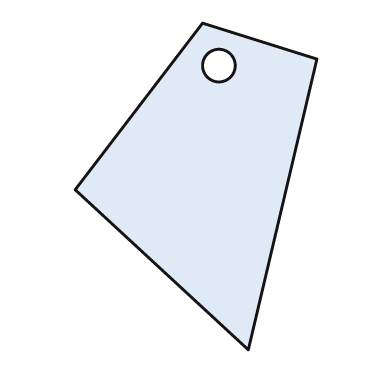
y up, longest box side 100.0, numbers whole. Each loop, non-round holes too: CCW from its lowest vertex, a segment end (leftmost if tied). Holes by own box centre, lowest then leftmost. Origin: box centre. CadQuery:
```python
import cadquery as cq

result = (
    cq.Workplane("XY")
    .moveTo(16.0, -50.0)
    .lineTo(37.0, 39.0)
    .lineTo(2.0, 50.0)
    .lineTo(-37.0, -1.0)
    .close()
    .moveTo(7.0, 37.0)
    .circle(5.0)
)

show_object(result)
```